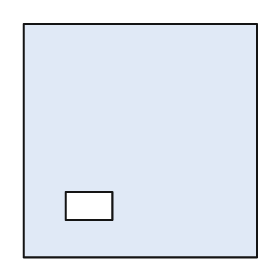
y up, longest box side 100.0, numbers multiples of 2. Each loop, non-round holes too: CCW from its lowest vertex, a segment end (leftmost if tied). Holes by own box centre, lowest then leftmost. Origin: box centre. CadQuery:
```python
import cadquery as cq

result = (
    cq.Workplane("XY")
    .moveTo(-50.0, -50.0)
    .lineTo(50.0, -50.0)
    .lineTo(50.0, 50.0)
    .lineTo(-50.0, 50.0)
    .close()
    .moveTo(-32.0, -34.0)
    .lineTo(-12.0, -34.0)
    .lineTo(-12.0, -22.0)
    .lineTo(-32.0, -22.0)
    .close()
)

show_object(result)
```